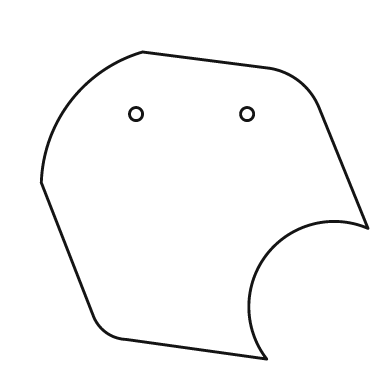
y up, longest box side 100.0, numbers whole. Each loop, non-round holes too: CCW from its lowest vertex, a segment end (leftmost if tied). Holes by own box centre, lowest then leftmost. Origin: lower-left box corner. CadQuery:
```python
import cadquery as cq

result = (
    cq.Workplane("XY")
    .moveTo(69.0, 0.0)
    .threePointArc((69.0, 32.0), (100.0, 40.0))
    .lineTo(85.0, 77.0)
    .threePointArc((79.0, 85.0), (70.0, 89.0))
    .lineTo(31.0, 94.0)
    .threePointArc((9.0, 79.0), (0.0, 54.0))
    .lineTo(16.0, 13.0)
    .threePointArc((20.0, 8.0), (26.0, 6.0))
    .close()
    .moveTo(29.0, 75.0)
    .circle(2.0)
    .moveTo(63.0, 75.0)
    .circle(2.0)
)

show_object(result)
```